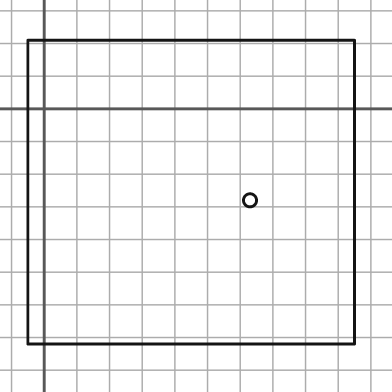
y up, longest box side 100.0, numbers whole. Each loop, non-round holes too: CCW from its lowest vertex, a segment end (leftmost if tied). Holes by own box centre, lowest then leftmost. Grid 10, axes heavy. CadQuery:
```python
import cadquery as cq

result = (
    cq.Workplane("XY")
    .moveTo(-5.0, -72.0)
    .lineTo(95.0, -72.0)
    .lineTo(95.0, 21.0)
    .lineTo(-5.0, 21.0)
    .close()
    .moveTo(63.0, -28.0)
    .circle(2.0)
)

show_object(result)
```